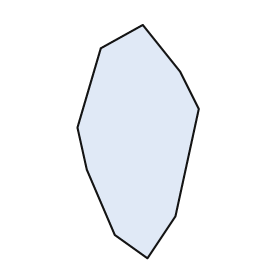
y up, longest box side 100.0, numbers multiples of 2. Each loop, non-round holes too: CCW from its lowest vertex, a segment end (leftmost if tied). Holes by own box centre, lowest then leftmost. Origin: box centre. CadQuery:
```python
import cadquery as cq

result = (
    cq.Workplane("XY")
    .moveTo(4.0, -50.0)
    .lineTo(16.0, -32.0)
    .lineTo(26.0, 14.0)
    .lineTo(18.0, 30.0)
    .lineTo(2.0, 50.0)
    .lineTo(-16.0, 40.0)
    .lineTo(-26.0, 6.0)
    .lineTo(-22.0, -12.0)
    .lineTo(-10.0, -40.0)
    .close()
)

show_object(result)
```